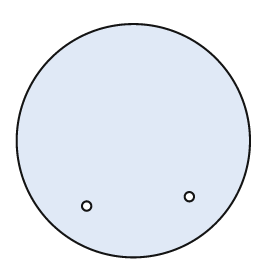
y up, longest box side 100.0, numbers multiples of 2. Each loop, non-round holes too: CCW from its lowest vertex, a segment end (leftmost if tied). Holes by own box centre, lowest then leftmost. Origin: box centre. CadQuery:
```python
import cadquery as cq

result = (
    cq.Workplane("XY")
    .moveTo(0.0, 0.0)
    .circle(50.0)
    .moveTo(-20.0, -28.0)
    .circle(2.0)
    .moveTo(24.0, -24.0)
    .circle(2.0)
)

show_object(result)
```